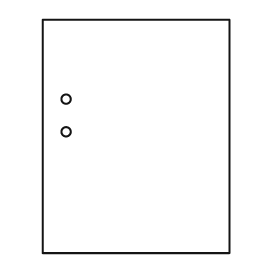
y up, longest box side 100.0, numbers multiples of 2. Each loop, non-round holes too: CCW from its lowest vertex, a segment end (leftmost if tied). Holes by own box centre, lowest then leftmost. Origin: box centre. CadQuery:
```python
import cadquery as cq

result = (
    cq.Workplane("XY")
    .moveTo(-40.0, -50.0)
    .lineTo(40.0, -50.0)
    .lineTo(40.0, 50.0)
    .lineTo(-40.0, 50.0)
    .close()
    .moveTo(-30.0, 2.0)
    .circle(2.0)
    .moveTo(-30.0, 16.0)
    .circle(2.0)
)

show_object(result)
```